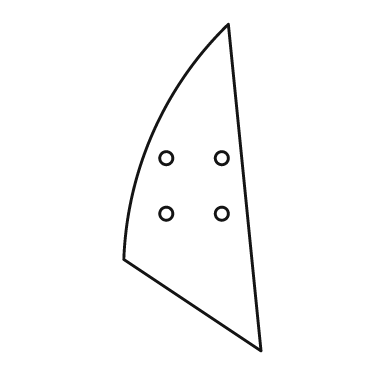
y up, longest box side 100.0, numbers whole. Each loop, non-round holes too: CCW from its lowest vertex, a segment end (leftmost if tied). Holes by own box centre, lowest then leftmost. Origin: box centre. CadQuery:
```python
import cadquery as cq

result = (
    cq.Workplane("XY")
    .moveTo(21.0, -50.0)
    .lineTo(11.0, 50.0)
    .threePointArc((-12.0, 17.0), (-21.0, -22.0))
    .close()
    .moveTo(-8.0, -8.0)
    .circle(2.0)
    .moveTo(9.0, -8.0)
    .circle(2.0)
    .moveTo(-8.0, 9.0)
    .circle(2.0)
    .moveTo(9.0, 9.0)
    .circle(2.0)
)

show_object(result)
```